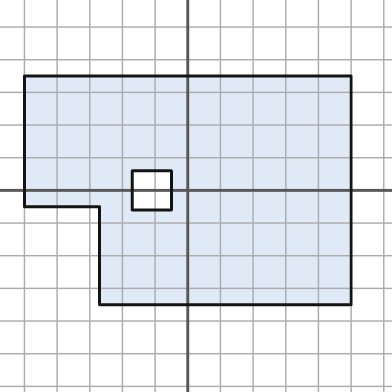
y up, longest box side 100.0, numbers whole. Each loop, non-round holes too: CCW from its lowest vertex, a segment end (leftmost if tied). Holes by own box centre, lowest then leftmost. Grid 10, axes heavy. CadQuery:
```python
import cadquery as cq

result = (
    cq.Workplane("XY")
    .moveTo(-27.0, -35.0)
    .lineTo(50.0, -35.0)
    .lineTo(50.0, 35.0)
    .lineTo(-50.0, 35.0)
    .lineTo(-50.0, -5.0)
    .lineTo(-27.0, -5.0)
    .close()
    .moveTo(-17.0, -6.0)
    .lineTo(-5.0, -6.0)
    .lineTo(-5.0, 6.0)
    .lineTo(-17.0, 6.0)
    .close()
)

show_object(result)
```